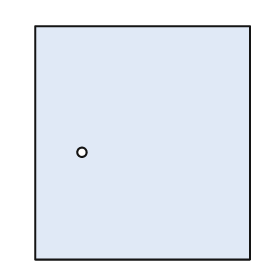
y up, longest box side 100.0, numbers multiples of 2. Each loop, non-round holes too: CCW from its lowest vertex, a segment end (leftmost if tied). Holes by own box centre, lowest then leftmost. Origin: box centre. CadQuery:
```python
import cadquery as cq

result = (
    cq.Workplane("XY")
    .moveTo(-46.0, -50.0)
    .lineTo(46.0, -50.0)
    .lineTo(46.0, 50.0)
    .lineTo(-46.0, 50.0)
    .close()
    .moveTo(-26.0, -4.0)
    .circle(2.0)
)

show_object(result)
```